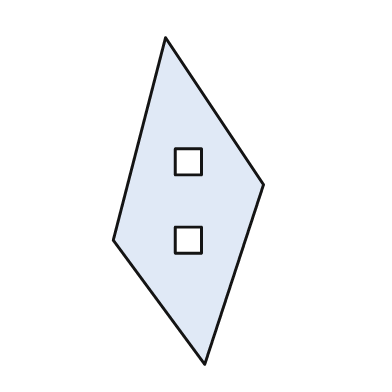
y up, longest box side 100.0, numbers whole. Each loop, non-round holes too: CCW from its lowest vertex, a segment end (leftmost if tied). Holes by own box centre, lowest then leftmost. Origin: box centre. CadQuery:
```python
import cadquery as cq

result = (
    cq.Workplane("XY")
    .moveTo(5.0, -50.0)
    .lineTo(23.0, 5.0)
    .lineTo(-7.0, 50.0)
    .lineTo(-23.0, -12.0)
    .close()
    .moveTo(-4.0, -16.0)
    .lineTo(4.0, -16.0)
    .lineTo(4.0, -8.0)
    .lineTo(-4.0, -8.0)
    .close()
    .moveTo(-4.0, 8.0)
    .lineTo(4.0, 8.0)
    .lineTo(4.0, 16.0)
    .lineTo(-4.0, 16.0)
    .close()
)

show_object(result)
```